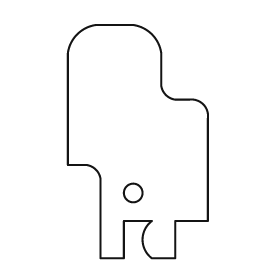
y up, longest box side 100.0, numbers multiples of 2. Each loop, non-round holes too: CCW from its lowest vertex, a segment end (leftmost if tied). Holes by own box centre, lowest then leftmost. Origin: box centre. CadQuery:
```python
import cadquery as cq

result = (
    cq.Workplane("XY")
    .moveTo(-16.0, -50.0)
    .lineTo(-6.0, -50.0)
    .lineTo(-6.0, -34.0)
    .lineTo(6.0, -34.0)
    .threePointArc((2.0, -42.0), (6.0, -50.0))
    .lineTo(16.0, -50.0)
    .lineTo(16.0, -34.0)
    .lineTo(30.0, -34.0)
    .lineTo(30.0, 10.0)
    .threePointArc((28.0, 16.0), (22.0, 18.0))
    .lineTo(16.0, 18.0)
    .threePointArc((12.0, 20.0), (10.0, 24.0))
    .lineTo(10.0, 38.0)
    .threePointArc((6.0, 46.0), (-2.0, 50.0))
    .lineTo(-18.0, 50.0)
    .threePointArc((-26.0, 46.0), (-30.0, 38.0))
    .lineTo(-30.0, -10.0)
    .lineTo(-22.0, -10.0)
    .threePointArc((-18.0, -12.0), (-16.0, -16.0))
    .close()
    .moveTo(-2.0, -22.0)
    .circle(4.0)
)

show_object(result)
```